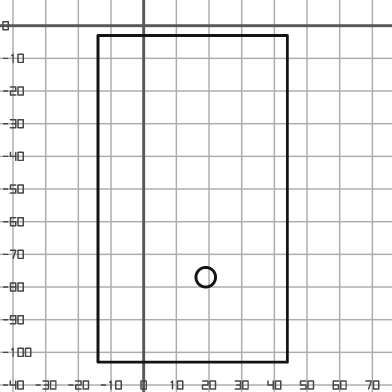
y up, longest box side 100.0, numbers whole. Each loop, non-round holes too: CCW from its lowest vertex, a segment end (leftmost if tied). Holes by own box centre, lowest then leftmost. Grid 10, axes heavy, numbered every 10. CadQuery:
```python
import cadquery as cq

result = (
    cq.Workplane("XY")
    .moveTo(-14.0, -103.0)
    .lineTo(44.0, -103.0)
    .lineTo(44.0, -3.0)
    .lineTo(-14.0, -3.0)
    .close()
    .moveTo(19.0, -77.0)
    .circle(3.0)
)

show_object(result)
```